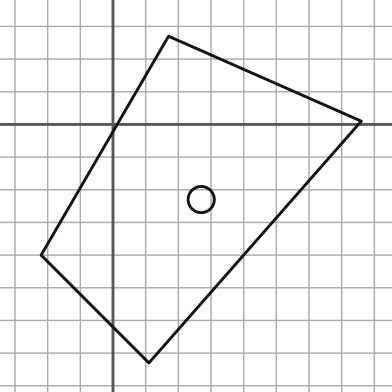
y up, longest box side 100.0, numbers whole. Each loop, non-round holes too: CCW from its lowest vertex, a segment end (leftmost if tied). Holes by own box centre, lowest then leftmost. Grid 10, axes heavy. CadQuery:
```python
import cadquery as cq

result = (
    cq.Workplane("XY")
    .moveTo(11.0, -73.0)
    .lineTo(76.0, 1.0)
    .lineTo(17.0, 27.0)
    .lineTo(-22.0, -40.0)
    .close()
    .moveTo(27.0, -23.0)
    .circle(4.0)
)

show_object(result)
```